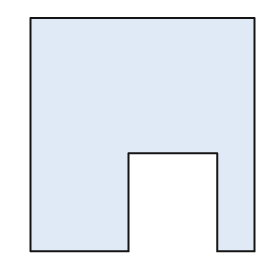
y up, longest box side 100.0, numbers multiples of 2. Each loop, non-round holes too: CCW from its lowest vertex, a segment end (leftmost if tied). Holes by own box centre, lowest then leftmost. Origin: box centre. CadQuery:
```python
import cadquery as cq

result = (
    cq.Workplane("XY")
    .moveTo(-48.0, -50.0)
    .lineTo(-6.0, -50.0)
    .lineTo(-6.0, -8.0)
    .lineTo(32.0, -8.0)
    .lineTo(32.0, -50.0)
    .lineTo(48.0, -50.0)
    .lineTo(48.0, 50.0)
    .lineTo(-48.0, 50.0)
    .close()
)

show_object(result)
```